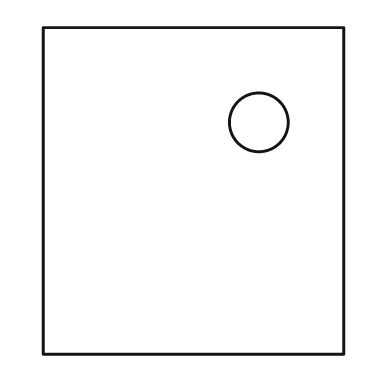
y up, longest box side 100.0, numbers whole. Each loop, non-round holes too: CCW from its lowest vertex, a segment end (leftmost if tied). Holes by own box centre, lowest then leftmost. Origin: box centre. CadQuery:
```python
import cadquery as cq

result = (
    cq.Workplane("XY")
    .moveTo(-46.0, -50.0)
    .lineTo(46.0, -50.0)
    .lineTo(46.0, 50.0)
    .lineTo(-46.0, 50.0)
    .close()
    .moveTo(20.0, 21.0)
    .circle(9.0)
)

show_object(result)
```